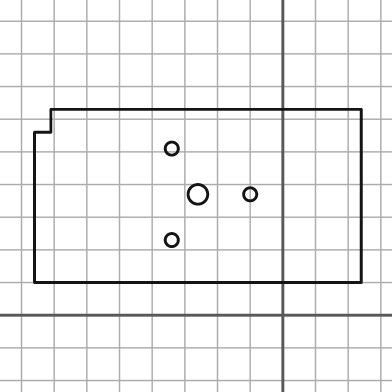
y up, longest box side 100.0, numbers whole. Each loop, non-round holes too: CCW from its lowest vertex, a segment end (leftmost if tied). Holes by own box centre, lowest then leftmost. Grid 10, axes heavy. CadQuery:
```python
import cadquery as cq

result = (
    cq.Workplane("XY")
    .moveTo(-76.0, 10.0)
    .lineTo(24.0, 10.0)
    .lineTo(24.0, 63.0)
    .lineTo(-71.0, 63.0)
    .lineTo(-71.0, 56.0)
    .lineTo(-76.0, 56.0)
    .close()
    .moveTo(-34.0, 23.0)
    .circle(2.0)
    .moveTo(-26.0, 37.0)
    .circle(3.0)
    .moveTo(-10.0, 37.0)
    .circle(2.0)
    .moveTo(-34.0, 51.0)
    .circle(2.0)
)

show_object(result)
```